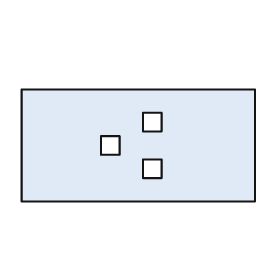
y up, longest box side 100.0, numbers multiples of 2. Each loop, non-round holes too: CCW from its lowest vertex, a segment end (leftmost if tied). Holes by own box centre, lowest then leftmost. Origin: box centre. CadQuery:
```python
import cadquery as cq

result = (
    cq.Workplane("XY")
    .moveTo(-50.0, -24.0)
    .lineTo(50.0, -24.0)
    .lineTo(50.0, 24.0)
    .lineTo(-50.0, 24.0)
    .close()
    .moveTo(2.0, -14.0)
    .lineTo(10.0, -14.0)
    .lineTo(10.0, -6.0)
    .lineTo(2.0, -6.0)
    .close()
    .moveTo(-16.0, -4.0)
    .lineTo(-8.0, -4.0)
    .lineTo(-8.0, 4.0)
    .lineTo(-16.0, 4.0)
    .close()
    .moveTo(2.0, 6.0)
    .lineTo(10.0, 6.0)
    .lineTo(10.0, 14.0)
    .lineTo(2.0, 14.0)
    .close()
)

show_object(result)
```